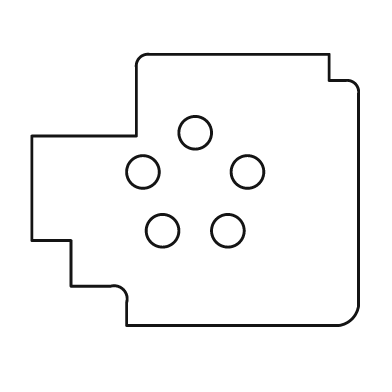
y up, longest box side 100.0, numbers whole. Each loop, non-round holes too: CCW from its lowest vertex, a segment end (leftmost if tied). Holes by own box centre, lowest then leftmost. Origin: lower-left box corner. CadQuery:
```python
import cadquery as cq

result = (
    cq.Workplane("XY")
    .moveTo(29.0, 0.0)
    .lineTo(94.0, 0.0)
    .threePointArc((98.0, 2.0), (100.0, 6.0))
    .lineTo(100.0, 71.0)
    .threePointArc((99.0, 74.0), (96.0, 75.0))
    .lineTo(91.0, 75.0)
    .lineTo(91.0, 83.0)
    .lineTo(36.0, 83.0)
    .threePointArc((33.0, 82.0), (32.0, 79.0))
    .lineTo(32.0, 58.0)
    .lineTo(0.0, 58.0)
    .lineTo(0.0, 26.0)
    .lineTo(12.0, 26.0)
    .lineTo(12.0, 12.0)
    .lineTo(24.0, 12.0)
    .threePointArc((28.0, 11.0), (29.0, 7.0))
    .close()
    .moveTo(40.0, 29.0)
    .circle(5.0)
    .moveTo(60.0, 29.0)
    .circle(5.0)
    .moveTo(34.0, 47.0)
    .circle(5.0)
    .moveTo(66.0, 47.0)
    .circle(5.0)
    .moveTo(50.0, 59.0)
    .circle(5.0)
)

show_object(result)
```